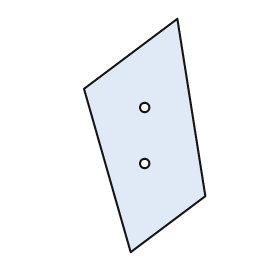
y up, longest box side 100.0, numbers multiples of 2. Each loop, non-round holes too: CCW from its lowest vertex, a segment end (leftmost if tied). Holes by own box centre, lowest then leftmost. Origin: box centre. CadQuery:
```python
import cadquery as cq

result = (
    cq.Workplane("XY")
    .moveTo(-6.0, -50.0)
    .lineTo(26.0, -26.0)
    .lineTo(14.0, 50.0)
    .lineTo(-26.0, 20.0)
    .close()
    .moveTo(0.0, -12.0)
    .circle(2.0)
    .moveTo(0.0, 12.0)
    .circle(2.0)
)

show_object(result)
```